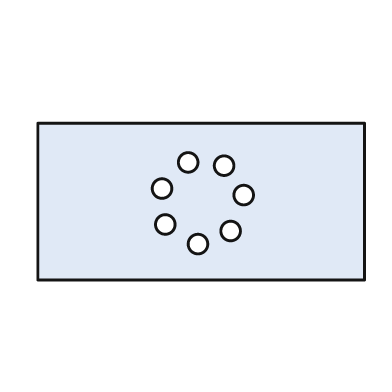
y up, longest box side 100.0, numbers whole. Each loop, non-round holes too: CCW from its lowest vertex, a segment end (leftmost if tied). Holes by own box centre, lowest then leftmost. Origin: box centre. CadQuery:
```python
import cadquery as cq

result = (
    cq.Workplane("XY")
    .moveTo(-50.0, -24.0)
    .lineTo(50.0, -24.0)
    .lineTo(50.0, 24.0)
    .lineTo(-50.0, 24.0)
    .close()
    .moveTo(-1.0, -13.0)
    .circle(3.0)
    .moveTo(9.0, -9.0)
    .circle(3.0)
    .moveTo(-11.0, -7.0)
    .circle(3.0)
    .moveTo(13.0, 2.0)
    .circle(3.0)
    .moveTo(-12.0, 4.0)
    .circle(3.0)
    .moveTo(7.0, 11.0)
    .circle(3.0)
    .moveTo(-4.0, 12.0)
    .circle(3.0)
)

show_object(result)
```